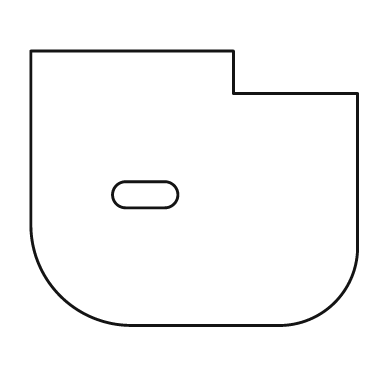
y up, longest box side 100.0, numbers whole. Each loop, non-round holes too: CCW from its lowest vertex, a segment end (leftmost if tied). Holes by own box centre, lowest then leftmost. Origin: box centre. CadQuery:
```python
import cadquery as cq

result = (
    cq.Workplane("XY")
    .moveTo(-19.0, -42.0)
    .lineTo(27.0, -42.0)
    .threePointArc((43.0, -35.0), (50.0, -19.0))
    .lineTo(50.0, 29.0)
    .lineTo(12.0, 29.0)
    .lineTo(12.0, 42.0)
    .lineTo(-50.0, 42.0)
    .lineTo(-50.0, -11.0)
    .threePointArc((-41.0, -33.0), (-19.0, -42.0))
    .close()
    .moveTo(-21.0, -6.0)
    .lineTo(-9.0, -6.0)
    .threePointArc((-5.0, -2.0), (-9.0, 2.0))
    .lineTo(-21.0, 2.0)
    .threePointArc((-25.0, -2.0), (-21.0, -6.0))
    .close()
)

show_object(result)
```